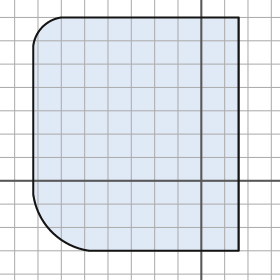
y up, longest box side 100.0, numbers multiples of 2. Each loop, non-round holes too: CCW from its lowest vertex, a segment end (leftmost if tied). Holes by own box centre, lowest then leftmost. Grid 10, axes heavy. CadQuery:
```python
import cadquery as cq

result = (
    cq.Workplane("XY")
    .moveTo(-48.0, -30.0)
    .lineTo(16.0, -30.0)
    .lineTo(16.0, 70.0)
    .lineTo(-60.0, 70.0)
    .threePointArc((-68.0, 66.0), (-72.0, 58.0))
    .lineTo(-72.0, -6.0)
    .threePointArc((-64.0, -22.0), (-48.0, -30.0))
    .close()
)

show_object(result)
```